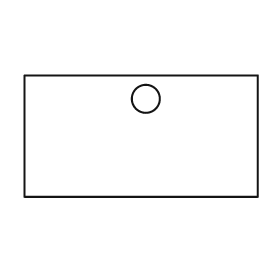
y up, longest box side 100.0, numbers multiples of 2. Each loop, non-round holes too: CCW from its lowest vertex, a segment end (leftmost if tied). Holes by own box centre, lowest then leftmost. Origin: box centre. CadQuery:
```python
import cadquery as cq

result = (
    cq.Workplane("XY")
    .moveTo(-50.0, -26.0)
    .lineTo(50.0, -26.0)
    .lineTo(50.0, 26.0)
    .lineTo(-50.0, 26.0)
    .close()
    .moveTo(2.0, 16.0)
    .circle(6.0)
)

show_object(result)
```